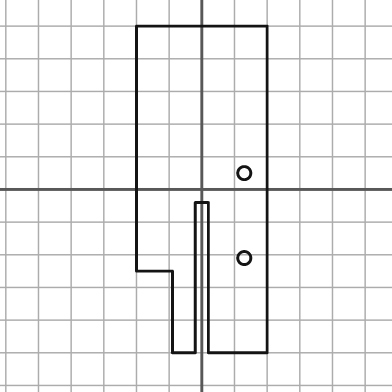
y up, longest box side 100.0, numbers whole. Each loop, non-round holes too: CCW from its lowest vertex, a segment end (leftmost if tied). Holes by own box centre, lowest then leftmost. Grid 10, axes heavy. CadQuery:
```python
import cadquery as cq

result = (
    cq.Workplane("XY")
    .moveTo(-9.0, -50.0)
    .lineTo(-2.0, -50.0)
    .lineTo(-2.0, -4.0)
    .lineTo(2.0, -4.0)
    .lineTo(2.0, -50.0)
    .lineTo(20.0, -50.0)
    .lineTo(20.0, 50.0)
    .lineTo(-20.0, 50.0)
    .lineTo(-20.0, -25.0)
    .lineTo(-9.0, -25.0)
    .close()
    .moveTo(13.0, -21.0)
    .circle(2.0)
    .moveTo(13.0, 5.0)
    .circle(2.0)
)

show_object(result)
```